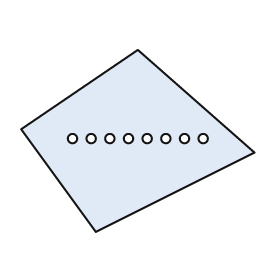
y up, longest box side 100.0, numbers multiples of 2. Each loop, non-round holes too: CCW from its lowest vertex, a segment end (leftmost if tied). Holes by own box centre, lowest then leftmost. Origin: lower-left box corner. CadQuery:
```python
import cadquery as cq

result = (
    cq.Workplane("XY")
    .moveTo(32.0, 0.0)
    .lineTo(100.0, 34.0)
    .lineTo(50.0, 78.0)
    .lineTo(0.0, 44.0)
    .close()
    .moveTo(22.0, 40.0)
    .circle(2.0)
    .moveTo(30.0, 40.0)
    .circle(2.0)
    .moveTo(38.0, 40.0)
    .circle(2.0)
    .moveTo(46.0, 40.0)
    .circle(2.0)
    .moveTo(54.0, 40.0)
    .circle(2.0)
    .moveTo(62.0, 40.0)
    .circle(2.0)
    .moveTo(70.0, 40.0)
    .circle(2.0)
    .moveTo(78.0, 40.0)
    .circle(2.0)
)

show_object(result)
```